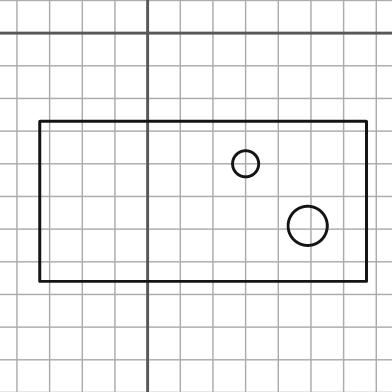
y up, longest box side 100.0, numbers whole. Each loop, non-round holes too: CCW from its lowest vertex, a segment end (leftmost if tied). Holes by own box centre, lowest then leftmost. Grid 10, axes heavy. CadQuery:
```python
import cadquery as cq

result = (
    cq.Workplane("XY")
    .moveTo(-33.0, -76.0)
    .lineTo(67.0, -76.0)
    .lineTo(67.0, -27.0)
    .lineTo(-33.0, -27.0)
    .close()
    .moveTo(49.0, -59.0)
    .circle(6.0)
    .moveTo(30.0, -40.0)
    .circle(4.0)
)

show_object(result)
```